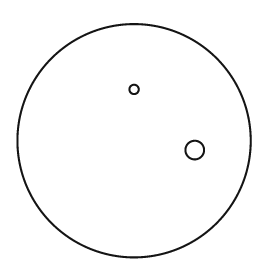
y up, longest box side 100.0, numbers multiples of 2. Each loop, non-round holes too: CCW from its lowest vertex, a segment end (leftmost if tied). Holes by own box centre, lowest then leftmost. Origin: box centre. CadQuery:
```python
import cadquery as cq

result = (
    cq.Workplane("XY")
    .moveTo(0.0, 0.0)
    .circle(50.0)
    .moveTo(26.0, -4.0)
    .circle(4.0)
    .moveTo(0.0, 22.0)
    .circle(2.0)
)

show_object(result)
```